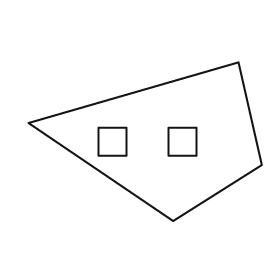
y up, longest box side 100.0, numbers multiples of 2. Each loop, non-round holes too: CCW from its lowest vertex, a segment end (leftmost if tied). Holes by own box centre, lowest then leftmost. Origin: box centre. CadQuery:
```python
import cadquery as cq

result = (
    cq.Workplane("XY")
    .moveTo(12.0, -34.0)
    .lineTo(50.0, -10.0)
    .lineTo(40.0, 34.0)
    .lineTo(-50.0, 8.0)
    .close()
    .moveTo(-20.0, -6.0)
    .lineTo(-8.0, -6.0)
    .lineTo(-8.0, 6.0)
    .lineTo(-20.0, 6.0)
    .close()
    .moveTo(10.0, -6.0)
    .lineTo(22.0, -6.0)
    .lineTo(22.0, 6.0)
    .lineTo(10.0, 6.0)
    .close()
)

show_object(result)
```